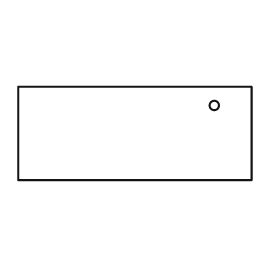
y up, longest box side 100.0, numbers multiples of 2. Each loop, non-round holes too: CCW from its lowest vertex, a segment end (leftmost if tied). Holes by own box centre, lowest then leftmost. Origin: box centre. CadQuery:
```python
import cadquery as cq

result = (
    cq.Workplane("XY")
    .moveTo(-50.0, -20.0)
    .lineTo(50.0, -20.0)
    .lineTo(50.0, 20.0)
    .lineTo(-50.0, 20.0)
    .close()
    .moveTo(34.0, 12.0)
    .circle(2.0)
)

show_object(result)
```